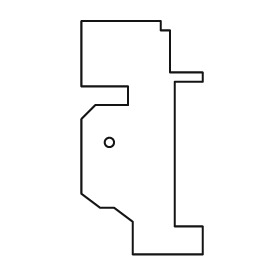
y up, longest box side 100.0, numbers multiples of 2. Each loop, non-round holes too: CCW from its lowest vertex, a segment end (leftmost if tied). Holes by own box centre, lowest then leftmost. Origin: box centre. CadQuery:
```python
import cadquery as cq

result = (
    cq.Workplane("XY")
    .moveTo(-4.0, -50.0)
    .lineTo(26.0, -50.0)
    .lineTo(26.0, -38.0)
    .lineTo(14.0, -38.0)
    .lineTo(14.0, 24.0)
    .lineTo(26.0, 24.0)
    .lineTo(26.0, 28.0)
    .lineTo(12.0, 28.0)
    .lineTo(12.0, 46.0)
    .lineTo(8.0, 46.0)
    .lineTo(8.0, 50.0)
    .lineTo(-26.0, 50.0)
    .lineTo(-26.0, 22.0)
    .lineTo(-6.0, 22.0)
    .lineTo(-6.0, 14.0)
    .lineTo(-20.0, 14.0)
    .lineTo(-26.0, 8.0)
    .lineTo(-26.0, -24.0)
    .lineTo(-18.0, -30.0)
    .lineTo(-12.0, -30.0)
    .lineTo(-4.0, -36.0)
    .close()
    .moveTo(-14.0, -2.0)
    .circle(2.0)
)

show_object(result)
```